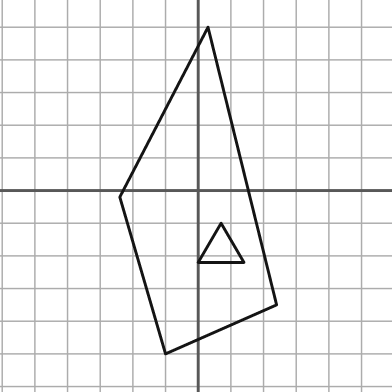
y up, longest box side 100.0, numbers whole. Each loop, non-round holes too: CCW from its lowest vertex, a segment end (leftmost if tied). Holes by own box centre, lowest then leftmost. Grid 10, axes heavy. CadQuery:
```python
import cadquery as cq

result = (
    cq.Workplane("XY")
    .moveTo(-10.0, -50.0)
    .lineTo(24.0, -35.0)
    .lineTo(3.0, 50.0)
    .lineTo(-24.0, -2.0)
    .close()
    .moveTo(0.0, -22.0)
    .lineTo(14.0, -22.0)
    .lineTo(7.0, -10.0)
    .close()
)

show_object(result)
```